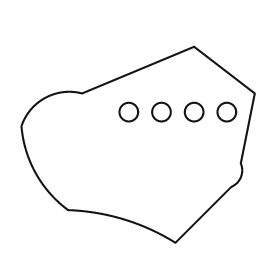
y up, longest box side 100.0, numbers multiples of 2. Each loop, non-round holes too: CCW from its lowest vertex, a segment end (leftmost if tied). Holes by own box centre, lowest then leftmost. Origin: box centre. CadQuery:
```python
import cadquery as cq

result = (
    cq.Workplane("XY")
    .moveTo(16.0, -42.0)
    .lineTo(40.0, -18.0)
    .threePointArc((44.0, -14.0), (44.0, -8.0))
    .lineTo(50.0, 22.0)
    .lineTo(24.0, 42.0)
    .lineTo(-24.0, 22.0)
    .threePointArc((-40.0, 20.0), (-50.0, 8.0))
    .threePointArc((-44.0, -12.0), (-30.0, -28.0))
    .threePointArc((-6.0, -32.0), (16.0, -42.0))
    .close()
    .moveTo(-4.0, 14.0)
    .circle(4.0)
    .moveTo(10.0, 14.0)
    .circle(4.0)
    .moveTo(24.0, 14.0)
    .circle(4.0)
    .moveTo(38.0, 14.0)
    .circle(4.0)
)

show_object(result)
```